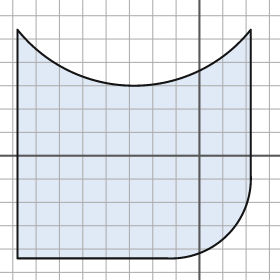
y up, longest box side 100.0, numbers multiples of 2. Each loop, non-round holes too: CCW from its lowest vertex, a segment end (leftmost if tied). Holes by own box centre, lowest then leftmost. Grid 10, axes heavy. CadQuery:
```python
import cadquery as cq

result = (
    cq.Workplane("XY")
    .moveTo(-78.0, -44.0)
    .lineTo(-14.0, -44.0)
    .threePointArc((12.0, -34.0), (22.0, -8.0))
    .lineTo(22.0, 54.0)
    .threePointArc((-28.0, 30.0), (-78.0, 54.0))
    .close()
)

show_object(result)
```